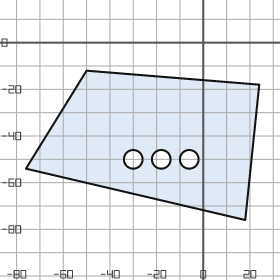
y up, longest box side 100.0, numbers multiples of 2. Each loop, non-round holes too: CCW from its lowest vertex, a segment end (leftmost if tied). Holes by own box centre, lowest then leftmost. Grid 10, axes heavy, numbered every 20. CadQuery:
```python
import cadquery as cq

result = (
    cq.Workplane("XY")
    .moveTo(18.0, -76.0)
    .lineTo(24.0, -18.0)
    .lineTo(-50.0, -12.0)
    .lineTo(-76.0, -54.0)
    .close()
    .moveTo(-30.0, -50.0)
    .circle(4.0)
    .moveTo(-18.0, -50.0)
    .circle(4.0)
    .moveTo(-6.0, -50.0)
    .circle(4.0)
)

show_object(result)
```